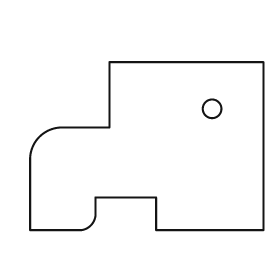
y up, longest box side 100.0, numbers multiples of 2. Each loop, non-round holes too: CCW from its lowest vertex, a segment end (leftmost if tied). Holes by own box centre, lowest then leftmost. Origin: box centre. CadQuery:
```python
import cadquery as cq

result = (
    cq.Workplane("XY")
    .moveTo(-50.0, -36.0)
    .lineTo(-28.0, -36.0)
    .threePointArc((-24.0, -34.0), (-22.0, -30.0))
    .lineTo(-22.0, -22.0)
    .lineTo(4.0, -22.0)
    .lineTo(4.0, -36.0)
    .lineTo(50.0, -36.0)
    .lineTo(50.0, 36.0)
    .lineTo(-16.0, 36.0)
    .lineTo(-16.0, 8.0)
    .lineTo(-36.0, 8.0)
    .threePointArc((-46.0, 4.0), (-50.0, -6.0))
    .close()
    .moveTo(28.0, 16.0)
    .circle(4.0)
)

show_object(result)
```